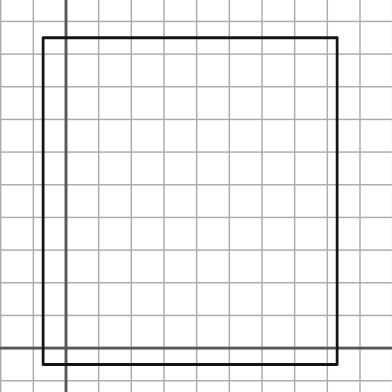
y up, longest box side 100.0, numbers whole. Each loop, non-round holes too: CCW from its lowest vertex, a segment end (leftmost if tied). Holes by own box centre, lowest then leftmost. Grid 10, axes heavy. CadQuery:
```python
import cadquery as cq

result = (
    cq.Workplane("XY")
    .moveTo(-7.0, -5.0)
    .lineTo(83.0, -5.0)
    .lineTo(83.0, 95.0)
    .lineTo(-7.0, 95.0)
    .close()
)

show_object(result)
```